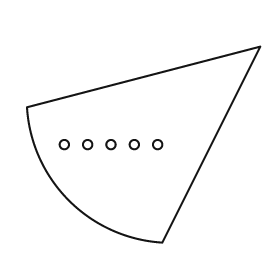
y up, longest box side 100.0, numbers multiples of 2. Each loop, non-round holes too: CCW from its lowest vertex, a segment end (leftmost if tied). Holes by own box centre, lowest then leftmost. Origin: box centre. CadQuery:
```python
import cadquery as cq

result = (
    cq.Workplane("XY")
    .moveTo(8.0, -42.0)
    .lineTo(50.0, 42.0)
    .lineTo(-50.0, 16.0)
    .threePointArc((-32.0, -24.0), (8.0, -42.0))
    .close()
    .moveTo(-34.0, 0.0)
    .circle(2.0)
    .moveTo(-24.0, 0.0)
    .circle(2.0)
    .moveTo(-14.0, 0.0)
    .circle(2.0)
    .moveTo(-4.0, 0.0)
    .circle(2.0)
    .moveTo(6.0, 0.0)
    .circle(2.0)
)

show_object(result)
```